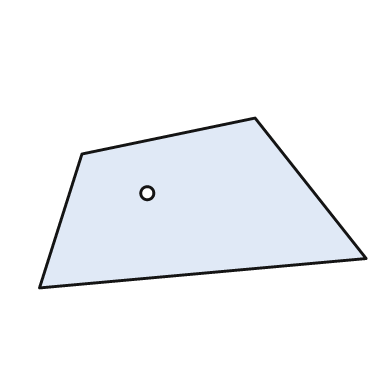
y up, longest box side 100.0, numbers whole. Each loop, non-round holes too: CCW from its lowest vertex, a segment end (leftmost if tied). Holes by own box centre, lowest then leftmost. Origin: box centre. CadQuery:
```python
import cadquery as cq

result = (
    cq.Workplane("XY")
    .moveTo(-50.0, -26.0)
    .lineTo(50.0, -17.0)
    .lineTo(16.0, 26.0)
    .lineTo(-37.0, 15.0)
    .close()
    .moveTo(-17.0, 3.0)
    .circle(2.0)
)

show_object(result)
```